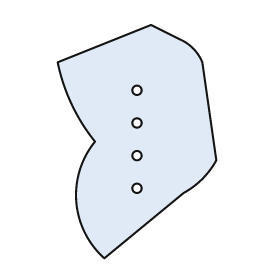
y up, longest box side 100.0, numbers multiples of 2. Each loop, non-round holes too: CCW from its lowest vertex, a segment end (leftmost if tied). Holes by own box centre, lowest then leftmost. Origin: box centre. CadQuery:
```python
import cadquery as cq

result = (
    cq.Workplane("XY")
    .moveTo(-14.0, -50.0)
    .lineTo(20.0, -22.0)
    .threePointArc((28.0, -16.0), (34.0, -8.0))
    .lineTo(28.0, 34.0)
    .threePointArc((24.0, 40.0), (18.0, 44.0))
    .lineTo(6.0, 50.0)
    .lineTo(-34.0, 34.0)
    .threePointArc((-28.0, 16.0), (-18.0, 0.0))
    .threePointArc((-26.0, -26.0), (-14.0, -50.0))
    .close()
    .moveTo(0.0, -20.0)
    .circle(2.0)
    .moveTo(0.0, -6.0)
    .circle(2.0)
    .moveTo(0.0, 8.0)
    .circle(2.0)
    .moveTo(0.0, 22.0)
    .circle(2.0)
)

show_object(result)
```